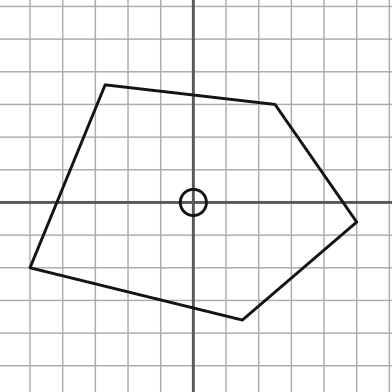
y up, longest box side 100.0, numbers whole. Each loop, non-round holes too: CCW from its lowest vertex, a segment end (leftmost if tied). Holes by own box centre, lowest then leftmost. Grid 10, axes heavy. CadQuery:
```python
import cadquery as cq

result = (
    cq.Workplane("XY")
    .moveTo(15.0, -36.0)
    .lineTo(50.0, -6.0)
    .lineTo(25.0, 30.0)
    .lineTo(-27.0, 36.0)
    .lineTo(-50.0, -20.0)
    .close()
    .moveTo(0.0, 0.0)
    .circle(4.0)
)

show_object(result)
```